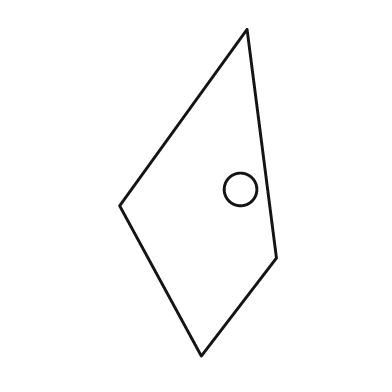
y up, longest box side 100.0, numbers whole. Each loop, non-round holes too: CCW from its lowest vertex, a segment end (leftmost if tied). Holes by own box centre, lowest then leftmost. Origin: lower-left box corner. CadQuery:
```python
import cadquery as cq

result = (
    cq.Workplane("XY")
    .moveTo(25.0, 0.0)
    .lineTo(48.0, 30.0)
    .lineTo(39.0, 100.0)
    .lineTo(0.0, 46.0)
    .close()
    .moveTo(37.0, 51.0)
    .circle(5.0)
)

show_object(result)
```